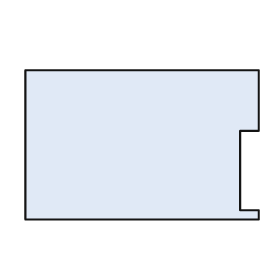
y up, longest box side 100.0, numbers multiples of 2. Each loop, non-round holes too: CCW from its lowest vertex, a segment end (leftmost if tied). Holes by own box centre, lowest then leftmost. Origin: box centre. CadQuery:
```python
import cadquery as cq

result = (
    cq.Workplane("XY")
    .moveTo(-50.0, -32.0)
    .lineTo(50.0, -32.0)
    .lineTo(50.0, -28.0)
    .lineTo(42.0, -28.0)
    .lineTo(42.0, 6.0)
    .lineTo(50.0, 6.0)
    .lineTo(50.0, 32.0)
    .lineTo(-50.0, 32.0)
    .close()
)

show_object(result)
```